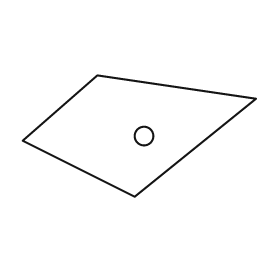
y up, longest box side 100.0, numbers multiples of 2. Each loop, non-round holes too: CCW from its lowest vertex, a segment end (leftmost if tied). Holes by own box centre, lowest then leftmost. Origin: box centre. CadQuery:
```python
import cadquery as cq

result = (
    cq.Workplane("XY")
    .moveTo(-2.0, -26.0)
    .lineTo(50.0, 16.0)
    .lineTo(-18.0, 26.0)
    .lineTo(-50.0, -2.0)
    .close()
    .moveTo(2.0, 0.0)
    .circle(4.0)
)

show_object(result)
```